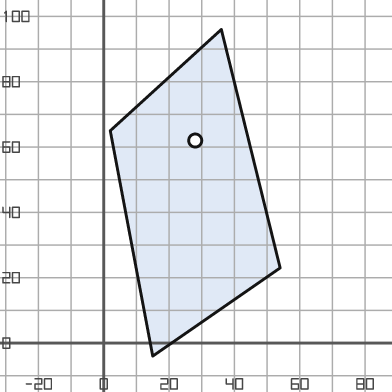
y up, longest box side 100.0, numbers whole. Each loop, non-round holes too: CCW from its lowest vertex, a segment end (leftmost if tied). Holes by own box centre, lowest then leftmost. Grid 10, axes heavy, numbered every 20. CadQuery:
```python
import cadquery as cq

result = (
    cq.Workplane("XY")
    .moveTo(15.0, -4.0)
    .lineTo(54.0, 23.0)
    .lineTo(36.0, 96.0)
    .lineTo(2.0, 65.0)
    .close()
    .moveTo(28.0, 62.0)
    .circle(2.0)
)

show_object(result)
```